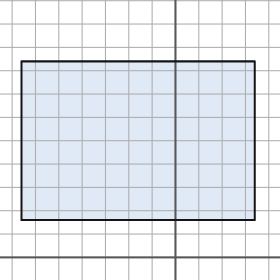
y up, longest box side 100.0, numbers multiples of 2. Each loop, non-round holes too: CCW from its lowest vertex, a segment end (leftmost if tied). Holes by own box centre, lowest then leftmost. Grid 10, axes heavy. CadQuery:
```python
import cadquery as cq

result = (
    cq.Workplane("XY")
    .moveTo(-66.0, 16.0)
    .lineTo(34.0, 16.0)
    .lineTo(34.0, 84.0)
    .lineTo(-66.0, 84.0)
    .close()
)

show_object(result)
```